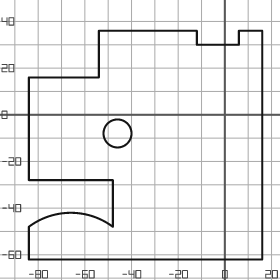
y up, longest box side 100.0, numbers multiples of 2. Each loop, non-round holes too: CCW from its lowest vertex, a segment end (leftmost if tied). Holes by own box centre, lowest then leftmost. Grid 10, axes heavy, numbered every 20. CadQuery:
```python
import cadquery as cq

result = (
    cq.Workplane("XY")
    .moveTo(-84.0, -62.0)
    .lineTo(16.0, -62.0)
    .lineTo(16.0, 36.0)
    .lineTo(6.0, 36.0)
    .lineTo(6.0, 30.0)
    .lineTo(-12.0, 30.0)
    .lineTo(-12.0, 36.0)
    .lineTo(-54.0, 36.0)
    .lineTo(-54.0, 16.0)
    .lineTo(-84.0, 16.0)
    .lineTo(-84.0, -28.0)
    .lineTo(-48.0, -28.0)
    .lineTo(-48.0, -48.0)
    .threePointArc((-66.0, -42.0), (-84.0, -48.0))
    .close()
    .moveTo(-46.0, -8.0)
    .circle(6.0)
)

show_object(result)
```